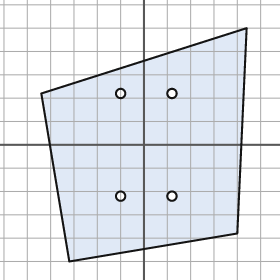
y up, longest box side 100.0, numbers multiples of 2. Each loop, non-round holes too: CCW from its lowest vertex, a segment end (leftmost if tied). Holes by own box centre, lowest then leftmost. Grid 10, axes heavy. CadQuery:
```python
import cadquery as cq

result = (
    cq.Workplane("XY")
    .moveTo(-32.0, -50.0)
    .lineTo(40.0, -38.0)
    .lineTo(44.0, 50.0)
    .lineTo(-44.0, 22.0)
    .close()
    .moveTo(-10.0, -22.0)
    .circle(2.0)
    .moveTo(12.0, -22.0)
    .circle(2.0)
    .moveTo(-10.0, 22.0)
    .circle(2.0)
    .moveTo(12.0, 22.0)
    .circle(2.0)
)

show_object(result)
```